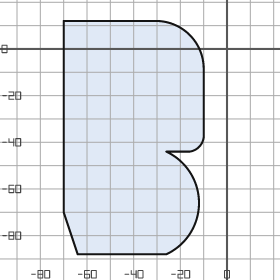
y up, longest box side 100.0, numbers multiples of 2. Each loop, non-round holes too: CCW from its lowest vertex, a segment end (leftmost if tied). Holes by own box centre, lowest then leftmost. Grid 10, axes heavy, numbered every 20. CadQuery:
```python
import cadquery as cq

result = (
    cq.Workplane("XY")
    .moveTo(-64.0, -88.0)
    .lineTo(-26.0, -88.0)
    .threePointArc((-12.0, -66.0), (-26.0, -44.0))
    .lineTo(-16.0, -44.0)
    .threePointArc((-12.0, -42.0), (-10.0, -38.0))
    .lineTo(-10.0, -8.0)
    .threePointArc((-16.0, 6.0), (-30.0, 12.0))
    .lineTo(-70.0, 12.0)
    .lineTo(-70.0, -70.0)
    .close()
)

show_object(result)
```